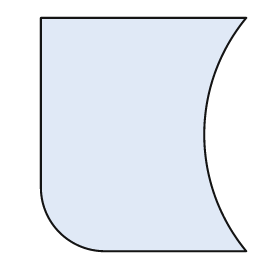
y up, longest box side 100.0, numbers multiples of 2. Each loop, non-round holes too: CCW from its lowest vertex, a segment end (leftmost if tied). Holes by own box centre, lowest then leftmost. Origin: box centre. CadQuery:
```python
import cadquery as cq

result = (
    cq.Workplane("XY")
    .moveTo(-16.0, -50.0)
    .lineTo(44.0, -50.0)
    .threePointArc((26.0, 0.0), (44.0, 50.0))
    .lineTo(-44.0, 50.0)
    .lineTo(-44.0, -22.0)
    .threePointArc((-36.0, -42.0), (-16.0, -50.0))
    .close()
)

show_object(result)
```